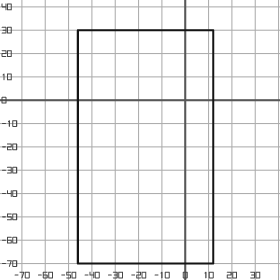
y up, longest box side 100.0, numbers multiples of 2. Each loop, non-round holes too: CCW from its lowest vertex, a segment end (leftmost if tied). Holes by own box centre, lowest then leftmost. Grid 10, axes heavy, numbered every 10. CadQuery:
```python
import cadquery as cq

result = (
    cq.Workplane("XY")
    .moveTo(-46.0, -70.0)
    .lineTo(12.0, -70.0)
    .lineTo(12.0, 30.0)
    .lineTo(-46.0, 30.0)
    .close()
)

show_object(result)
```